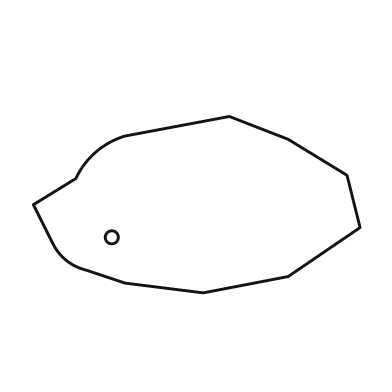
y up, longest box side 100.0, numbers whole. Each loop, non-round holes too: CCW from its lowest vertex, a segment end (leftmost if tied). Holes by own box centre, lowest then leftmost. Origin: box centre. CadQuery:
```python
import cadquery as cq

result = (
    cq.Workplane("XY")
    .moveTo(2.0, -27.0)
    .lineTo(28.0, -22.0)
    .lineTo(50.0, -7.0)
    .lineTo(46.0, 9.0)
    .lineTo(28.0, 20.0)
    .lineTo(10.0, 27.0)
    .lineTo(-22.0, 21.0)
    .threePointArc((-31.0, 16.0), (-37.0, 8.0))
    .lineTo(-50.0, 0.0)
    .lineTo(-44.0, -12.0)
    .threePointArc((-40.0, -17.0), (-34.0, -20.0))
    .lineTo(-22.0, -24.0)
    .close()
    .moveTo(-26.0, -10.0)
    .circle(2.0)
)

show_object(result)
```